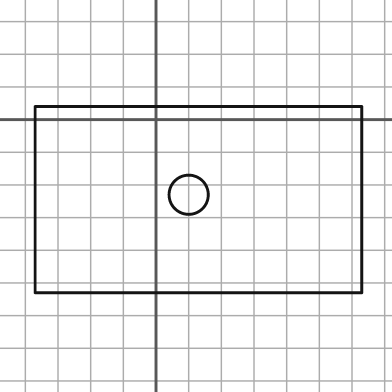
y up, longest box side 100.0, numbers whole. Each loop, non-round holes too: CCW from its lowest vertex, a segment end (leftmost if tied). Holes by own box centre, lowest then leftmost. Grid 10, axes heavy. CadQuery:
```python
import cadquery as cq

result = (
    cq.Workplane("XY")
    .moveTo(-37.0, -53.0)
    .lineTo(63.0, -53.0)
    .lineTo(63.0, 4.0)
    .lineTo(-37.0, 4.0)
    .close()
    .moveTo(10.0, -23.0)
    .circle(6.0)
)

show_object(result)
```